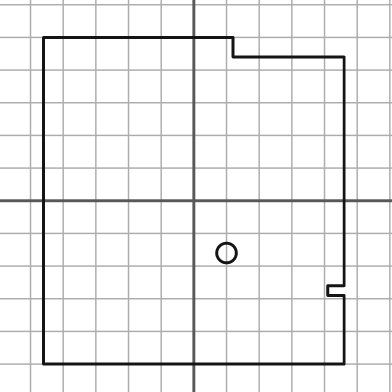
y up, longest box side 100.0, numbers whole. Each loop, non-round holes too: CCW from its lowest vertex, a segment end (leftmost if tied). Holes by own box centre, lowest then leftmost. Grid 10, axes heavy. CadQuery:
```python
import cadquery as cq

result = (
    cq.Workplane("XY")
    .moveTo(-46.0, -50.0)
    .lineTo(46.0, -50.0)
    .lineTo(46.0, -29.0)
    .lineTo(41.0, -29.0)
    .lineTo(41.0, -26.0)
    .lineTo(46.0, -26.0)
    .lineTo(46.0, 44.0)
    .lineTo(12.0, 44.0)
    .lineTo(12.0, 50.0)
    .lineTo(-46.0, 50.0)
    .close()
    .moveTo(10.0, -16.0)
    .circle(3.0)
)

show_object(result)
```